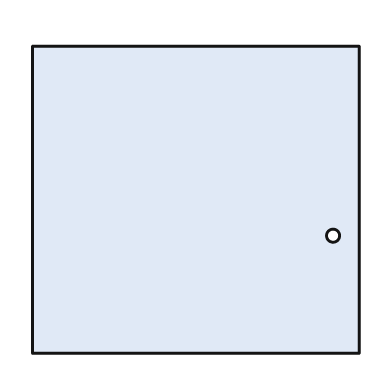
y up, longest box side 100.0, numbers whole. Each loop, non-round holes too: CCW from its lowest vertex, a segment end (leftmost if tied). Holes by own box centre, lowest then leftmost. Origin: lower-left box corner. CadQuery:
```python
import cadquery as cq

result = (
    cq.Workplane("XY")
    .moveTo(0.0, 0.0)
    .lineTo(100.0, 0.0)
    .lineTo(100.0, 94.0)
    .lineTo(0.0, 94.0)
    .close()
    .moveTo(92.0, 36.0)
    .circle(2.0)
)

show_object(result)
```